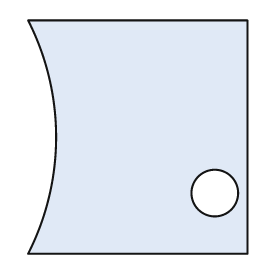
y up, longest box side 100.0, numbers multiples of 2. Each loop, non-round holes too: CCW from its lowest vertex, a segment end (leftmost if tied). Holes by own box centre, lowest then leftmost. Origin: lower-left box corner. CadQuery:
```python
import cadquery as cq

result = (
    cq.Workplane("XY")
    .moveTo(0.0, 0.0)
    .lineTo(94.0, 0.0)
    .lineTo(94.0, 100.0)
    .lineTo(0.0, 100.0)
    .threePointArc((12.0, 50.0), (0.0, 0.0))
    .close()
    .moveTo(80.0, 26.0)
    .circle(10.0)
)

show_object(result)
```